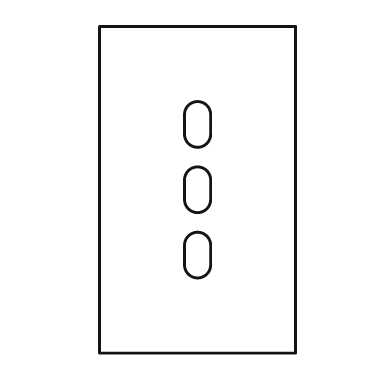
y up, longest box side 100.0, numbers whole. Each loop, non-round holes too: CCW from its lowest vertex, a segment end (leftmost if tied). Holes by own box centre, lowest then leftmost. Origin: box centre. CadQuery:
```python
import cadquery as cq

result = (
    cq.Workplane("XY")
    .moveTo(-30.0, -50.0)
    .lineTo(30.0, -50.0)
    .lineTo(30.0, 50.0)
    .lineTo(-30.0, 50.0)
    .close()
    .moveTo(-4.0, -23.0)
    .threePointArc((0.0, -27.0), (4.0, -23.0))
    .lineTo(4.0, -17.0)
    .threePointArc((0.0, -13.0), (-4.0, -17.0))
    .close()
    .moveTo(-4.0, -3.0)
    .threePointArc((0.0, -7.0), (4.0, -3.0))
    .lineTo(4.0, 3.0)
    .threePointArc((0.0, 7.0), (-4.0, 3.0))
    .close()
    .moveTo(-4.0, 17.0)
    .threePointArc((0.0, 13.0), (4.0, 17.0))
    .lineTo(4.0, 23.0)
    .threePointArc((0.0, 27.0), (-4.0, 23.0))
    .close()
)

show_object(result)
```